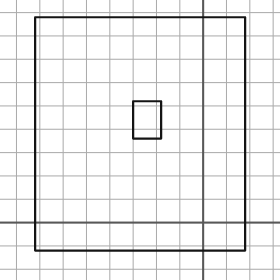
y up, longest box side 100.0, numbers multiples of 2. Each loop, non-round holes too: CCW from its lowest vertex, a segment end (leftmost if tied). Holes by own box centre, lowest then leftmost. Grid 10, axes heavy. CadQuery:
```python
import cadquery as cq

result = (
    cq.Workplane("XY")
    .moveTo(-72.0, -12.0)
    .lineTo(18.0, -12.0)
    .lineTo(18.0, 88.0)
    .lineTo(-72.0, 88.0)
    .close()
    .moveTo(-30.0, 36.0)
    .lineTo(-18.0, 36.0)
    .lineTo(-18.0, 52.0)
    .lineTo(-30.0, 52.0)
    .close()
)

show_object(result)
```